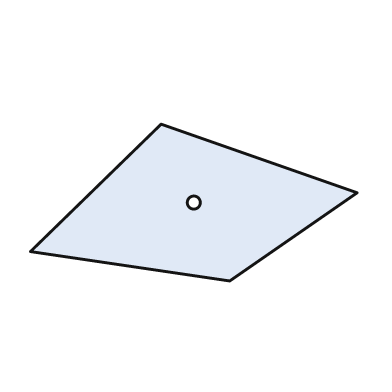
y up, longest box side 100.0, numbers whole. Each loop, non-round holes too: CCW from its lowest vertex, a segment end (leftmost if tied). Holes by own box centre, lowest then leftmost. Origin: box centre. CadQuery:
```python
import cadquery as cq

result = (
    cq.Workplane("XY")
    .moveTo(11.0, -24.0)
    .lineTo(50.0, 3.0)
    .lineTo(-10.0, 24.0)
    .lineTo(-50.0, -15.0)
    .close()
    .moveTo(0.0, 0.0)
    .circle(2.0)
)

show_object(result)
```